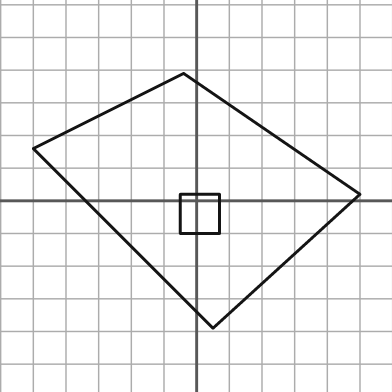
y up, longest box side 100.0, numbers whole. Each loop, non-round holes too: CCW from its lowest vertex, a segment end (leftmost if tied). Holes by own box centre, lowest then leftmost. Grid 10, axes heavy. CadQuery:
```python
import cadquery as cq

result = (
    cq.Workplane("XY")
    .moveTo(5.0, -39.0)
    .lineTo(50.0, 2.0)
    .lineTo(-4.0, 39.0)
    .lineTo(-50.0, 16.0)
    .close()
    .moveTo(-5.0, -10.0)
    .lineTo(7.0, -10.0)
    .lineTo(7.0, 2.0)
    .lineTo(-5.0, 2.0)
    .close()
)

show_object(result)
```